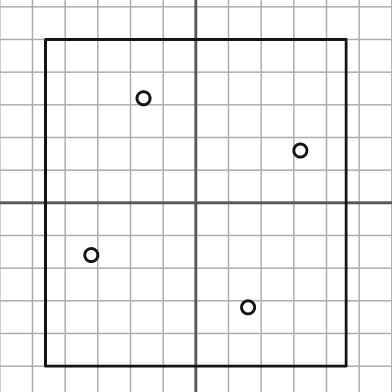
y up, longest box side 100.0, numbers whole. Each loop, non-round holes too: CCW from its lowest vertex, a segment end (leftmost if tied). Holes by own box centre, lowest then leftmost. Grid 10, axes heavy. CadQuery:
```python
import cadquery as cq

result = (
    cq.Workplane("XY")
    .moveTo(-46.0, -50.0)
    .lineTo(46.0, -50.0)
    .lineTo(46.0, 50.0)
    .lineTo(-46.0, 50.0)
    .close()
    .moveTo(16.0, -32.0)
    .circle(2.0)
    .moveTo(-32.0, -16.0)
    .circle(2.0)
    .moveTo(32.0, 16.0)
    .circle(2.0)
    .moveTo(-16.0, 32.0)
    .circle(2.0)
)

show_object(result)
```